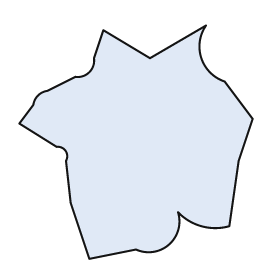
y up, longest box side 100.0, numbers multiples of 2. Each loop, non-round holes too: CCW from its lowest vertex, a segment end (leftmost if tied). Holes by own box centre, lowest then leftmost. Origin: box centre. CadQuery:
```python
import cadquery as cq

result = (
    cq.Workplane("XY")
    .moveTo(-20.0, -50.0)
    .lineTo(0.0, -46.0)
    .threePointArc((14.0, -44.0), (18.0, -30.0))
    .threePointArc((28.0, -36.0), (40.0, -36.0))
    .lineTo(44.0, -8.0)
    .lineTo(50.0, 10.0)
    .lineTo(38.0, 26.0)
    .threePointArc((28.0, 36.0), (30.0, 50.0))
    .lineTo(6.0, 36.0)
    .lineTo(-14.0, 48.0)
    .lineTo(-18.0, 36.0)
    .threePointArc((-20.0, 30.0), (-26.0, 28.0))
    .lineTo(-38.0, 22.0)
    .threePointArc((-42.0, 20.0), (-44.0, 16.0))
    .lineTo(-50.0, 8.0)
    .lineTo(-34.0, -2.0)
    .threePointArc((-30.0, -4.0), (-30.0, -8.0))
    .lineTo(-28.0, -26.0)
    .close()
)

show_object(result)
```